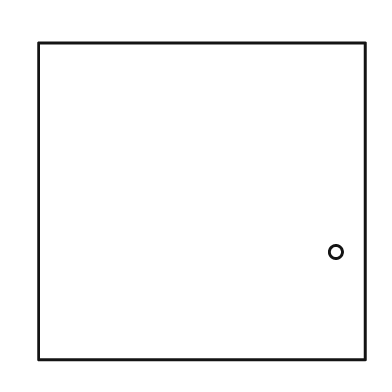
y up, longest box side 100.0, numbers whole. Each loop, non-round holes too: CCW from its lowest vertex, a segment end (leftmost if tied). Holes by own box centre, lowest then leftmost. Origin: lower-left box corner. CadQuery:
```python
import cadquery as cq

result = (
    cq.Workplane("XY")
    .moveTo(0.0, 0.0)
    .lineTo(100.0, 0.0)
    .lineTo(100.0, 97.0)
    .lineTo(0.0, 97.0)
    .close()
    .moveTo(91.0, 33.0)
    .circle(2.0)
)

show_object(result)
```